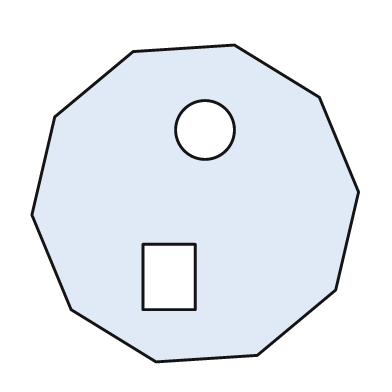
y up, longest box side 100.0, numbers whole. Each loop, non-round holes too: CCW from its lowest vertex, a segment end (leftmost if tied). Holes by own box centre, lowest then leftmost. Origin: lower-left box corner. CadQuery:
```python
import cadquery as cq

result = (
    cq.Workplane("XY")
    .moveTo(38.0, 0.0)
    .lineTo(69.0, 2.0)
    .lineTo(93.0, 22.0)
    .lineTo(100.0, 52.0)
    .lineTo(88.0, 81.0)
    .lineTo(62.0, 97.0)
    .lineTo(31.0, 95.0)
    .lineTo(7.0, 75.0)
    .lineTo(0.0, 45.0)
    .lineTo(12.0, 16.0)
    .close()
    .moveTo(34.0, 16.0)
    .lineTo(50.0, 16.0)
    .lineTo(50.0, 36.0)
    .lineTo(34.0, 36.0)
    .close()
    .moveTo(53.0, 71.0)
    .circle(9.0)
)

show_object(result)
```